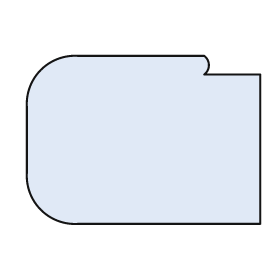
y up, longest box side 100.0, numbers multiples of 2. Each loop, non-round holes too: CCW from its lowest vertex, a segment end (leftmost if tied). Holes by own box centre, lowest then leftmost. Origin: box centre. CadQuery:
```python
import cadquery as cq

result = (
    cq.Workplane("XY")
    .moveTo(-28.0, -36.0)
    .lineTo(50.0, -36.0)
    .lineTo(50.0, 28.0)
    .lineTo(26.0, 28.0)
    .threePointArc((28.0, 32.0), (26.0, 36.0))
    .lineTo(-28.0, 36.0)
    .threePointArc((-44.0, 30.0), (-50.0, 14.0))
    .lineTo(-50.0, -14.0)
    .threePointArc((-44.0, -30.0), (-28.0, -36.0))
    .close()
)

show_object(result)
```